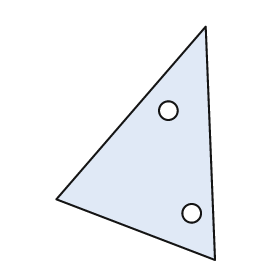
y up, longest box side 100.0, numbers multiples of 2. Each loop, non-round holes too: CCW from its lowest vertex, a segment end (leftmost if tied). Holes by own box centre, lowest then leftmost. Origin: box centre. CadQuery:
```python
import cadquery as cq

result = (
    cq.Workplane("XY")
    .moveTo(34.0, -50.0)
    .lineTo(30.0, 50.0)
    .lineTo(-34.0, -24.0)
    .close()
    .moveTo(24.0, -30.0)
    .circle(4.0)
    .moveTo(14.0, 14.0)
    .circle(4.0)
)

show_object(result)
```